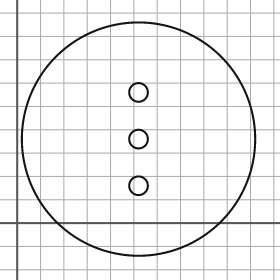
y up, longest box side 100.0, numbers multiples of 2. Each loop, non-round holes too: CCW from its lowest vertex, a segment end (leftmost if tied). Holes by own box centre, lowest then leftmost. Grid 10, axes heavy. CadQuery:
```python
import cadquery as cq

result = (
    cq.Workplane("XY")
    .moveTo(52.0, 36.0)
    .circle(50.0)
    .moveTo(52.0, 16.0)
    .circle(4.0)
    .moveTo(52.0, 36.0)
    .circle(4.0)
    .moveTo(52.0, 56.0)
    .circle(4.0)
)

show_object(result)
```